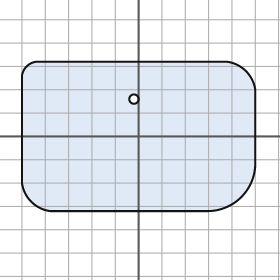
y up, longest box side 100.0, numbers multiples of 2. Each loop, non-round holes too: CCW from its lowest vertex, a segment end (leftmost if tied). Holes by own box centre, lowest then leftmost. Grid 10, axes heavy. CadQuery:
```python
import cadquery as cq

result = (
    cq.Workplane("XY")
    .moveTo(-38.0, -32.0)
    .lineTo(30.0, -32.0)
    .threePointArc((44.0, -26.0), (50.0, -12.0))
    .lineTo(50.0, 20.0)
    .threePointArc((46.0, 28.0), (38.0, 32.0))
    .lineTo(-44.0, 32.0)
    .threePointArc((-48.0, 30.0), (-50.0, 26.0))
    .lineTo(-50.0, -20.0)
    .threePointArc((-46.0, -28.0), (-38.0, -32.0))
    .close()
    .moveTo(-2.0, 16.0)
    .circle(2.0)
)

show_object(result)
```